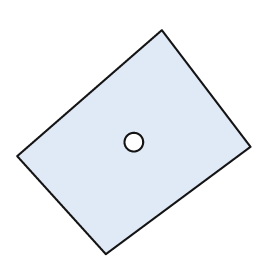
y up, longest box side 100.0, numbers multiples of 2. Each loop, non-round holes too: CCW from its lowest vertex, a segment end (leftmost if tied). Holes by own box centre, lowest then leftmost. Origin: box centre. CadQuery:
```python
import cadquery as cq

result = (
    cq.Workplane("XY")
    .moveTo(-12.0, -48.0)
    .lineTo(50.0, -2.0)
    .lineTo(12.0, 48.0)
    .lineTo(-50.0, -6.0)
    .close()
    .moveTo(0.0, 0.0)
    .circle(4.0)
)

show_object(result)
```